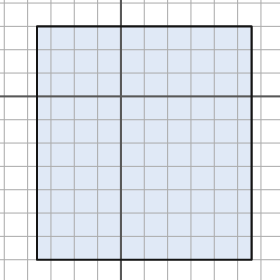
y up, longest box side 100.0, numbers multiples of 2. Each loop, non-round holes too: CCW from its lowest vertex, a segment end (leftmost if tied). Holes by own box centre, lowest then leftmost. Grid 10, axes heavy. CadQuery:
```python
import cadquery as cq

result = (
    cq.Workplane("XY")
    .moveTo(-36.0, -70.0)
    .lineTo(56.0, -70.0)
    .lineTo(56.0, 30.0)
    .lineTo(-36.0, 30.0)
    .close()
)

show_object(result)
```